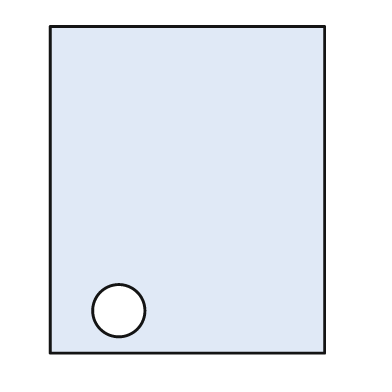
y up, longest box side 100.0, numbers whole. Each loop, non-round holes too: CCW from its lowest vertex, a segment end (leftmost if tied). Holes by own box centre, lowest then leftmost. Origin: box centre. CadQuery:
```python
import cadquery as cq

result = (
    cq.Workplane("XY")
    .moveTo(-42.0, -50.0)
    .lineTo(42.0, -50.0)
    .lineTo(42.0, 50.0)
    .lineTo(-42.0, 50.0)
    .close()
    .moveTo(-21.0, -37.0)
    .circle(8.0)
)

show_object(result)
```